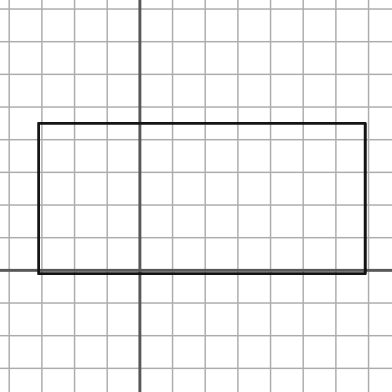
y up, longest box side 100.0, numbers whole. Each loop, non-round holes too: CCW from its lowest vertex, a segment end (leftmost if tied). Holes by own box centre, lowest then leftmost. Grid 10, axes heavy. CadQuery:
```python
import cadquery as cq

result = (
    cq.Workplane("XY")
    .moveTo(-31.0, -1.0)
    .lineTo(69.0, -1.0)
    .lineTo(69.0, 45.0)
    .lineTo(-31.0, 45.0)
    .close()
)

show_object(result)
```